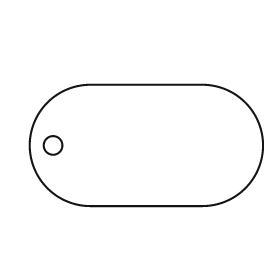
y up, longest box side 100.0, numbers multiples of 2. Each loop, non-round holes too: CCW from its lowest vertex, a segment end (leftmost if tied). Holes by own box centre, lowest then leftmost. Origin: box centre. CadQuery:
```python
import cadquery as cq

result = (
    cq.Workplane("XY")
    .moveTo(-24.0, -26.0)
    .lineTo(24.0, -26.0)
    .threePointArc((50.0, 0.0), (24.0, 26.0))
    .lineTo(-24.0, 26.0)
    .threePointArc((-50.0, 0.0), (-24.0, -26.0))
    .close()
    .moveTo(-40.0, 0.0)
    .circle(4.0)
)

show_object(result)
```